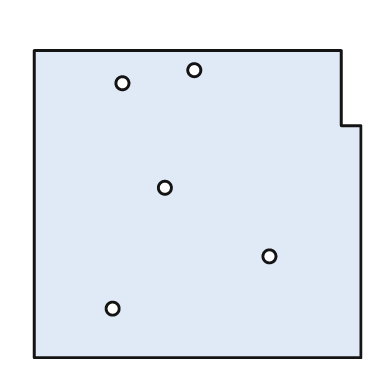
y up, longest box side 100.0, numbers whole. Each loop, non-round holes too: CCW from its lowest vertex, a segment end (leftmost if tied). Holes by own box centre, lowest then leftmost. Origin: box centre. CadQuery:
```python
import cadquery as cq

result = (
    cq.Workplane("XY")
    .moveTo(-50.0, -47.0)
    .lineTo(50.0, -47.0)
    .lineTo(50.0, 24.0)
    .lineTo(44.0, 24.0)
    .lineTo(44.0, 47.0)
    .lineTo(-50.0, 47.0)
    .close()
    .moveTo(-26.0, -32.0)
    .circle(2.0)
    .moveTo(22.0, -16.0)
    .circle(2.0)
    .moveTo(-10.0, 5.0)
    .circle(2.0)
    .moveTo(-23.0, 37.0)
    .circle(2.0)
    .moveTo(-1.0, 41.0)
    .circle(2.0)
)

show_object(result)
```